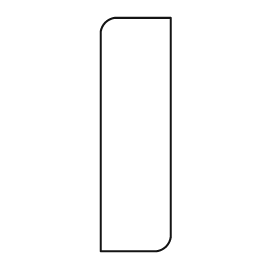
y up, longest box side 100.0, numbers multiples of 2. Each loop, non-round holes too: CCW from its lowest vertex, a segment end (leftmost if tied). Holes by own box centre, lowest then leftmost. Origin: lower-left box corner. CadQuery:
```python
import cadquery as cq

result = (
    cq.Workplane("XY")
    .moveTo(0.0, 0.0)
    .lineTo(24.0, 0.0)
    .threePointArc((28.0, 2.0), (30.0, 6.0))
    .lineTo(30.0, 100.0)
    .lineTo(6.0, 100.0)
    .threePointArc((2.0, 98.0), (0.0, 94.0))
    .close()
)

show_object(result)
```